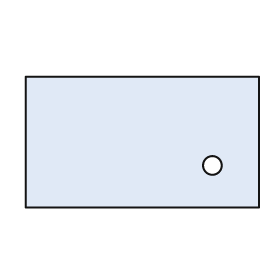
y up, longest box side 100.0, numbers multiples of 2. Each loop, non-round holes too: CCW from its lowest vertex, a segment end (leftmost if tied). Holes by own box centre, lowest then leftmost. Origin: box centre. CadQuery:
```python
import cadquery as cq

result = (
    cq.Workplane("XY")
    .moveTo(-50.0, -28.0)
    .lineTo(50.0, -28.0)
    .lineTo(50.0, 28.0)
    .lineTo(-50.0, 28.0)
    .close()
    .moveTo(30.0, -10.0)
    .circle(4.0)
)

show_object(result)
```